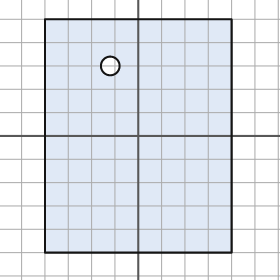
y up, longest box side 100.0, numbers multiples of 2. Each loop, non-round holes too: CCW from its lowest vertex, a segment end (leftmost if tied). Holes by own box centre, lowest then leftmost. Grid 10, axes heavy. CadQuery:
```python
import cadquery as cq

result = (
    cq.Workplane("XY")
    .moveTo(-40.0, -50.0)
    .lineTo(40.0, -50.0)
    .lineTo(40.0, 50.0)
    .lineTo(-40.0, 50.0)
    .close()
    .moveTo(-12.0, 30.0)
    .circle(4.0)
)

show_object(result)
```